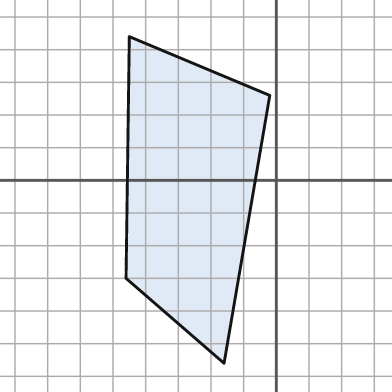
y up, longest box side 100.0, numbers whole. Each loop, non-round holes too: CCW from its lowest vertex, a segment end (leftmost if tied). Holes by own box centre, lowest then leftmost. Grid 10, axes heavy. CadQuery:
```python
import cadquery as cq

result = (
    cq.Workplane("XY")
    .moveTo(-16.0, -56.0)
    .lineTo(-2.0, 26.0)
    .lineTo(-45.0, 44.0)
    .lineTo(-46.0, -30.0)
    .close()
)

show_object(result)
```